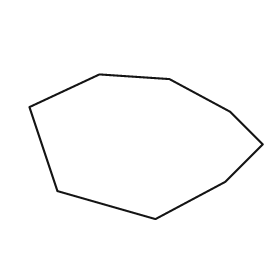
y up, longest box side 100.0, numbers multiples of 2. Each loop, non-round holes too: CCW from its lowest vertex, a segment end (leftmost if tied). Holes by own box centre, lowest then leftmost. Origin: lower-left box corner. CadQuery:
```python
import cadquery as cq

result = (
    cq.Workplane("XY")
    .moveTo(54.0, 0.0)
    .lineTo(84.0, 16.0)
    .lineTo(100.0, 32.0)
    .lineTo(86.0, 46.0)
    .lineTo(60.0, 60.0)
    .lineTo(30.0, 62.0)
    .lineTo(0.0, 48.0)
    .lineTo(12.0, 12.0)
    .close()
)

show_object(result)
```